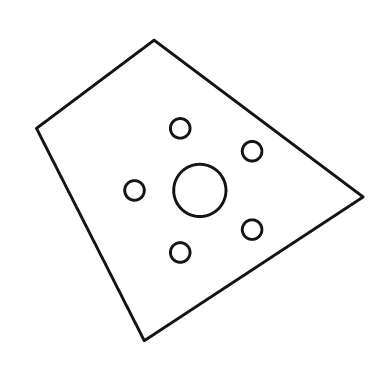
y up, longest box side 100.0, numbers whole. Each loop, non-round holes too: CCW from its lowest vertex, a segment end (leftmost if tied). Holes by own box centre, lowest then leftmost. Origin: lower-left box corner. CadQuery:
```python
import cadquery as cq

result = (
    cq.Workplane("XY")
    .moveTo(33.0, 0.0)
    .lineTo(100.0, 44.0)
    .lineTo(36.0, 92.0)
    .lineTo(0.0, 65.0)
    .close()
    .moveTo(44.0, 27.0)
    .circle(3.0)
    .moveTo(66.0, 34.0)
    .circle(3.0)
    .moveTo(30.0, 46.0)
    .circle(3.0)
    .moveTo(50.0, 46.0)
    .circle(8.0)
    .moveTo(66.0, 58.0)
    .circle(3.0)
    .moveTo(44.0, 65.0)
    .circle(3.0)
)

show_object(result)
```